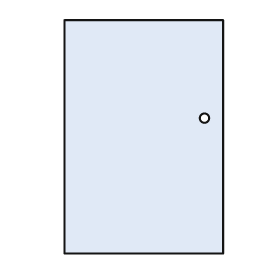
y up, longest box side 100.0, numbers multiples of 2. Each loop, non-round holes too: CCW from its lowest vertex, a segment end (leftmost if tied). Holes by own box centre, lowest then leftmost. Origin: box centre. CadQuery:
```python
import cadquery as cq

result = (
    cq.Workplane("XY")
    .moveTo(-34.0, -50.0)
    .lineTo(34.0, -50.0)
    .lineTo(34.0, 50.0)
    .lineTo(-34.0, 50.0)
    .close()
    .moveTo(26.0, 8.0)
    .circle(2.0)
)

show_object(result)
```